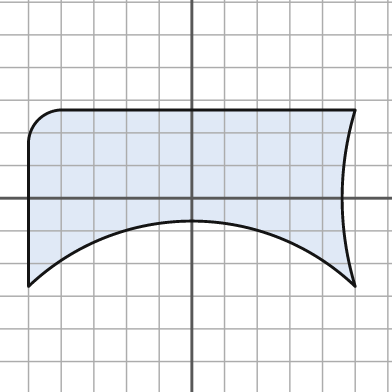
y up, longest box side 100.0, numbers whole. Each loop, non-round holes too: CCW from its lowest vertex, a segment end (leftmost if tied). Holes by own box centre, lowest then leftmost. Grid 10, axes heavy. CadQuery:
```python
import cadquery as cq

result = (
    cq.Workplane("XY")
    .moveTo(-50.0, -27.0)
    .threePointArc((0.0, -7.0), (50.0, -27.0))
    .threePointArc((46.0, 0.0), (50.0, 27.0))
    .lineTo(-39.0, 27.0)
    .threePointArc((-47.0, 24.0), (-50.0, 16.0))
    .close()
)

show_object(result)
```